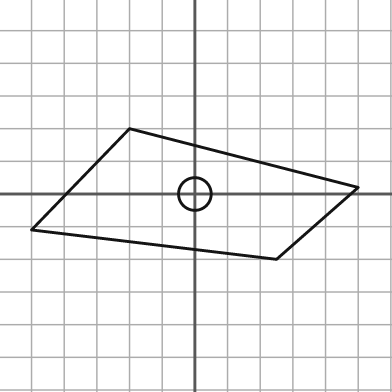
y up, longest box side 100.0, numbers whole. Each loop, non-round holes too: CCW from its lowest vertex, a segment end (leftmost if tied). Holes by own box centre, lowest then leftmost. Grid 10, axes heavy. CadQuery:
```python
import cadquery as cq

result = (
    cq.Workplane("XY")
    .moveTo(25.0, -20.0)
    .lineTo(50.0, 2.0)
    .lineTo(-20.0, 20.0)
    .lineTo(-50.0, -11.0)
    .close()
    .moveTo(0.0, 0.0)
    .circle(5.0)
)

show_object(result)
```